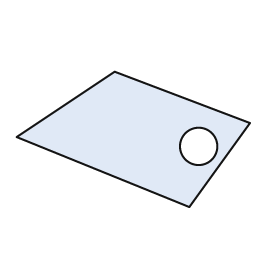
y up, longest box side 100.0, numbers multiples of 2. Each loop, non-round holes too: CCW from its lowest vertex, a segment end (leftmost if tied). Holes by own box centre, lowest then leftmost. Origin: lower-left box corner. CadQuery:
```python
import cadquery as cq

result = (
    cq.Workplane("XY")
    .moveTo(74.0, 0.0)
    .lineTo(100.0, 36.0)
    .lineTo(42.0, 58.0)
    .lineTo(0.0, 30.0)
    .close()
    .moveTo(78.0, 26.0)
    .circle(8.0)
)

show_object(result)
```